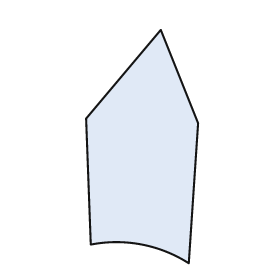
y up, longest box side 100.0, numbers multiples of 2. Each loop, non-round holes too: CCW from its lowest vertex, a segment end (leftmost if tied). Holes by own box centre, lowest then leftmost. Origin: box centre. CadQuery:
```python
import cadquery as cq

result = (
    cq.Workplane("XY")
    .moveTo(20.0, -50.0)
    .lineTo(24.0, 10.0)
    .lineTo(8.0, 50.0)
    .lineTo(-24.0, 12.0)
    .lineTo(-22.0, -42.0)
    .threePointArc((0.0, -42.0), (20.0, -50.0))
    .close()
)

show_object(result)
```